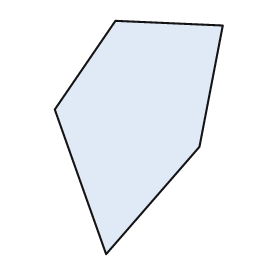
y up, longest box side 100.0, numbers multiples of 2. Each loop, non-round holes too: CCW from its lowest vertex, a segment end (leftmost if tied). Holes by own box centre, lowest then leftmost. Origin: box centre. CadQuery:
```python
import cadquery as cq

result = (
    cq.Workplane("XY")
    .moveTo(-14.0, -50.0)
    .lineTo(26.0, -4.0)
    .lineTo(36.0, 48.0)
    .lineTo(-10.0, 50.0)
    .lineTo(-36.0, 12.0)
    .close()
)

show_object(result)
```